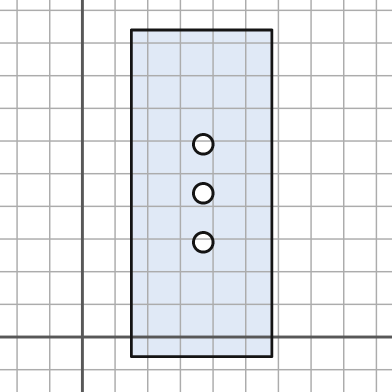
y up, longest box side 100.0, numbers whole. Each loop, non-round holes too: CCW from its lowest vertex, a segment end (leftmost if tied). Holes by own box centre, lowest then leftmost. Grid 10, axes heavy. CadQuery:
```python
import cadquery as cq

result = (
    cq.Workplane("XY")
    .moveTo(15.0, -6.0)
    .lineTo(58.0, -6.0)
    .lineTo(58.0, 94.0)
    .lineTo(15.0, 94.0)
    .close()
    .moveTo(37.0, 29.0)
    .circle(3.0)
    .moveTo(37.0, 44.0)
    .circle(3.0)
    .moveTo(37.0, 59.0)
    .circle(3.0)
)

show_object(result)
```